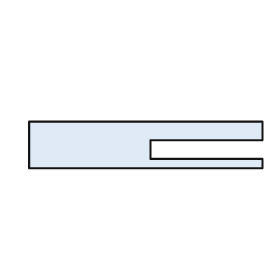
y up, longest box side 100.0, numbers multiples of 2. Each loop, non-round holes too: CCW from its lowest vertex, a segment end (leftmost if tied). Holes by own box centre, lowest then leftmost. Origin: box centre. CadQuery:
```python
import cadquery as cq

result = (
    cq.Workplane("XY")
    .moveTo(-50.0, -10.0)
    .lineTo(50.0, -10.0)
    .lineTo(50.0, -6.0)
    .lineTo(2.0, -6.0)
    .lineTo(2.0, 2.0)
    .lineTo(50.0, 2.0)
    .lineTo(50.0, 10.0)
    .lineTo(-50.0, 10.0)
    .close()
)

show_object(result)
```